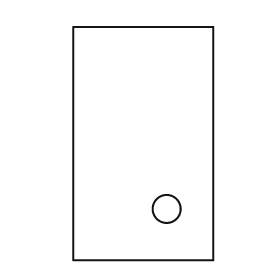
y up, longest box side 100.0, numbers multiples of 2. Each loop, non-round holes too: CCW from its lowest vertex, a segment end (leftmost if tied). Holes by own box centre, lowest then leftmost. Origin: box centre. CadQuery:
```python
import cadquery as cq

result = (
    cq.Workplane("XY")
    .moveTo(-30.0, -50.0)
    .lineTo(30.0, -50.0)
    .lineTo(30.0, 50.0)
    .lineTo(-30.0, 50.0)
    .close()
    .moveTo(10.0, -28.0)
    .circle(6.0)
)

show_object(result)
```